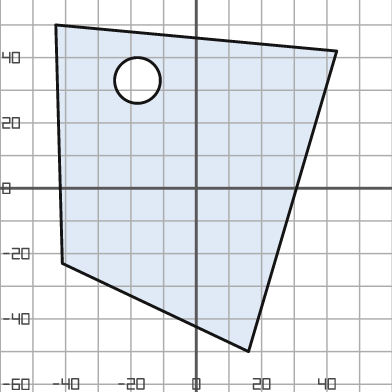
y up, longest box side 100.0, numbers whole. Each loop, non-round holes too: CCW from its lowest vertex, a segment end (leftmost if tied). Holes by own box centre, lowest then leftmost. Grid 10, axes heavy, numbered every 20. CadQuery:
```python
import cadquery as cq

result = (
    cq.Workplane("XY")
    .moveTo(16.0, -50.0)
    .lineTo(43.0, 42.0)
    .lineTo(-43.0, 50.0)
    .lineTo(-41.0, -23.0)
    .close()
    .moveTo(-18.0, 33.0)
    .circle(7.0)
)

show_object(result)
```